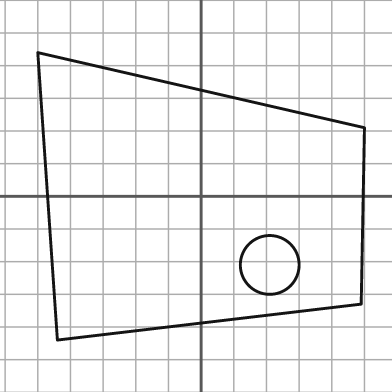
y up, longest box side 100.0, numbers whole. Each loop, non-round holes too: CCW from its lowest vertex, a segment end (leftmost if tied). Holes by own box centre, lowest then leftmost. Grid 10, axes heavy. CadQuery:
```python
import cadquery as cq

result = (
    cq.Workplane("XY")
    .moveTo(-44.0, -44.0)
    .lineTo(49.0, -33.0)
    .lineTo(50.0, 21.0)
    .lineTo(-50.0, 44.0)
    .close()
    .moveTo(21.0, -21.0)
    .circle(9.0)
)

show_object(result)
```